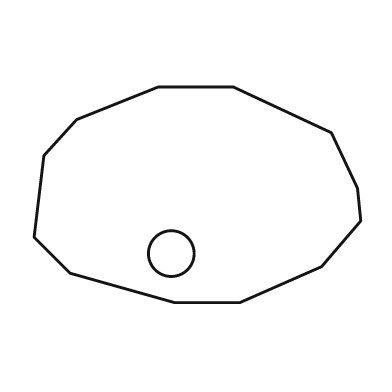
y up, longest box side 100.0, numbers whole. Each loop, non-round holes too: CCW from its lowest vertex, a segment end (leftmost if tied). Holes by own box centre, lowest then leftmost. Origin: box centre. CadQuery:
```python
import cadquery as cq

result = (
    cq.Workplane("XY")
    .moveTo(-7.0, -33.0)
    .lineTo(13.0, -33.0)
    .lineTo(38.0, -22.0)
    .lineTo(50.0, -8.0)
    .lineTo(49.0, 2.0)
    .lineTo(41.0, 19.0)
    .lineTo(11.0, 33.0)
    .lineTo(-12.0, 33.0)
    .lineTo(-37.0, 23.0)
    .lineTo(-47.0, 12.0)
    .lineTo(-50.0, -13.0)
    .lineTo(-39.0, -24.0)
    .close()
    .moveTo(-8.0, -18.0)
    .circle(7.0)
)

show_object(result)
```